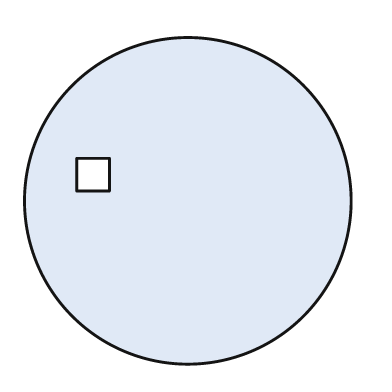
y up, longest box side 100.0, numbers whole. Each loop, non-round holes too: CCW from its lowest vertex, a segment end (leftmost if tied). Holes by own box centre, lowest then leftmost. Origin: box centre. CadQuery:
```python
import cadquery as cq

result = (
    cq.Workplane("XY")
    .moveTo(0.0, 0.0)
    .circle(50.0)
    .moveTo(-34.0, 3.0)
    .lineTo(-24.0, 3.0)
    .lineTo(-24.0, 13.0)
    .lineTo(-34.0, 13.0)
    .close()
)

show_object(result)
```